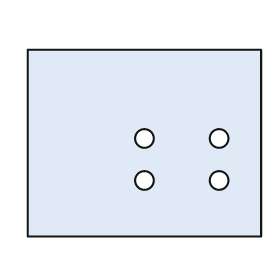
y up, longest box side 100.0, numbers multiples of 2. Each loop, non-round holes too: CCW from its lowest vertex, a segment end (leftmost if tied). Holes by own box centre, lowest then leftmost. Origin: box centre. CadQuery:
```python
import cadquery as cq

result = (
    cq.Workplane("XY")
    .moveTo(-50.0, -40.0)
    .lineTo(50.0, -40.0)
    .lineTo(50.0, 40.0)
    .lineTo(-50.0, 40.0)
    .close()
    .moveTo(0.0, -16.0)
    .circle(4.0)
    .moveTo(32.0, -16.0)
    .circle(4.0)
    .moveTo(0.0, 2.0)
    .circle(4.0)
    .moveTo(32.0, 2.0)
    .circle(4.0)
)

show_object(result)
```